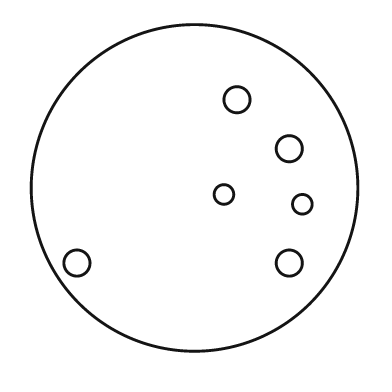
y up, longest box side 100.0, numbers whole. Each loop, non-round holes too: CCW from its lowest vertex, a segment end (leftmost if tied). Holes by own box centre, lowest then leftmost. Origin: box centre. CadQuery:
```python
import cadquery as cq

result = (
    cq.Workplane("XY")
    .moveTo(0.0, 0.0)
    .circle(50.0)
    .moveTo(-36.0, -23.0)
    .circle(4.0)
    .moveTo(29.0, -23.0)
    .circle(4.0)
    .moveTo(33.0, -5.0)
    .circle(3.0)
    .moveTo(9.0, -2.0)
    .circle(3.0)
    .moveTo(29.0, 12.0)
    .circle(4.0)
    .moveTo(13.0, 27.0)
    .circle(4.0)
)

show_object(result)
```